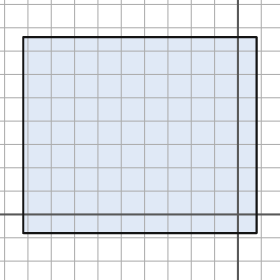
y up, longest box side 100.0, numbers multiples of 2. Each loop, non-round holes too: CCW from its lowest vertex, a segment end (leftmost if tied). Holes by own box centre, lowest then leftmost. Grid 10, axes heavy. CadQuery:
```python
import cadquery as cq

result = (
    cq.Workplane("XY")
    .moveTo(-92.0, -8.0)
    .lineTo(8.0, -8.0)
    .lineTo(8.0, 76.0)
    .lineTo(-92.0, 76.0)
    .close()
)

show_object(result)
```